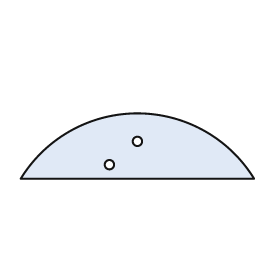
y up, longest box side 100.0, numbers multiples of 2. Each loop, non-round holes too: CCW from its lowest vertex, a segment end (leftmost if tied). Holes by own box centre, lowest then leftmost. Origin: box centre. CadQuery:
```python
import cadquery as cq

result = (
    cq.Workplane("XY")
    .moveTo(-50.0, -14.0)
    .lineTo(50.0, -14.0)
    .threePointArc((0.0, 14.0), (-50.0, -14.0))
    .close()
    .moveTo(-12.0, -8.0)
    .circle(2.0)
    .moveTo(0.0, 2.0)
    .circle(2.0)
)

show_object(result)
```